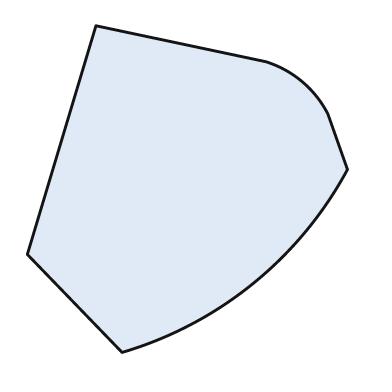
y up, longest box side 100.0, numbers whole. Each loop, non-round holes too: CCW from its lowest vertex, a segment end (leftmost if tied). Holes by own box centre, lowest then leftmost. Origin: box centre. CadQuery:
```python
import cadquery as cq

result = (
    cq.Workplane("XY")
    .moveTo(-20.0, -50.0)
    .threePointArc((20.0, -29.0), (49.0, 6.0))
    .lineTo(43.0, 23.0)
    .threePointArc((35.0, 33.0), (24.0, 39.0))
    .lineTo(-28.0, 50.0)
    .lineTo(-49.0, -20.0)
    .close()
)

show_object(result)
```